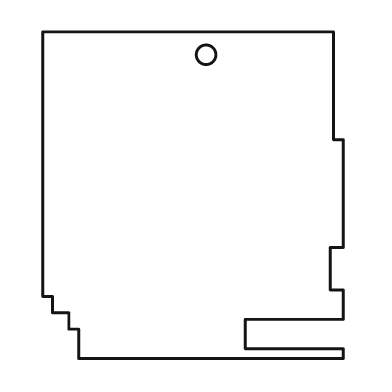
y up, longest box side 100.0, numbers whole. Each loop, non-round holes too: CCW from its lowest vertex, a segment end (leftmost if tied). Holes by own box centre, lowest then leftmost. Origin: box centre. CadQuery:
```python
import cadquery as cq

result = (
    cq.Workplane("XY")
    .moveTo(-35.0, -50.0)
    .lineTo(46.0, -50.0)
    .lineTo(46.0, -47.0)
    .lineTo(16.0, -47.0)
    .lineTo(16.0, -38.0)
    .lineTo(46.0, -38.0)
    .lineTo(46.0, -29.0)
    .lineTo(42.0, -29.0)
    .lineTo(42.0, -16.0)
    .lineTo(46.0, -16.0)
    .lineTo(46.0, 17.0)
    .lineTo(43.0, 17.0)
    .lineTo(43.0, 50.0)
    .lineTo(-46.0, 50.0)
    .lineTo(-46.0, -31.0)
    .lineTo(-43.0, -31.0)
    .lineTo(-43.0, -36.0)
    .lineTo(-38.0, -36.0)
    .lineTo(-38.0, -41.0)
    .lineTo(-35.0, -41.0)
    .close()
    .moveTo(4.0, 43.0)
    .circle(3.0)
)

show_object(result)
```